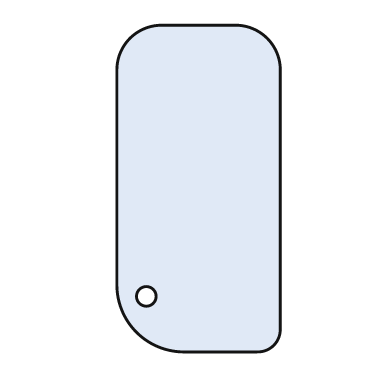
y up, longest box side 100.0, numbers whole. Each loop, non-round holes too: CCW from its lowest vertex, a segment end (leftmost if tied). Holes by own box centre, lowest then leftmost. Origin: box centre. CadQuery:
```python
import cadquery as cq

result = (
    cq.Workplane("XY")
    .moveTo(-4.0, -50.0)
    .lineTo(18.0, -50.0)
    .threePointArc((23.0, -48.0), (25.0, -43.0))
    .lineTo(25.0, 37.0)
    .threePointArc((21.0, 46.0), (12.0, 50.0))
    .lineTo(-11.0, 50.0)
    .threePointArc((-21.0, 46.0), (-25.0, 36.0))
    .lineTo(-25.0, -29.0)
    .threePointArc((-19.0, -44.0), (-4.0, -50.0))
    .close()
    .moveTo(-16.0, -33.0)
    .circle(3.0)
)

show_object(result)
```